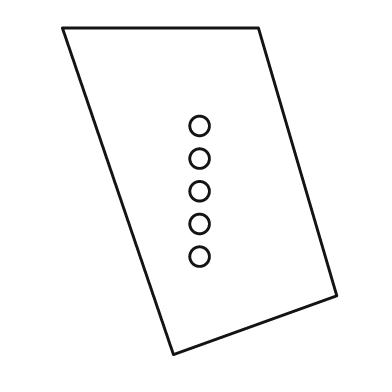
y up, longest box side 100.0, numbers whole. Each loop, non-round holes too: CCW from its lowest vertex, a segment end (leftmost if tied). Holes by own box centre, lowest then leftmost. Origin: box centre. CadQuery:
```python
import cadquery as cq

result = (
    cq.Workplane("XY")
    .moveTo(-8.0, -50.0)
    .lineTo(42.0, -32.0)
    .lineTo(18.0, 50.0)
    .lineTo(-42.0, 50.0)
    .close()
    .moveTo(0.0, -20.0)
    .circle(3.0)
    .moveTo(0.0, -10.0)
    .circle(3.0)
    .moveTo(0.0, 0.0)
    .circle(3.0)
    .moveTo(0.0, 10.0)
    .circle(3.0)
    .moveTo(0.0, 20.0)
    .circle(3.0)
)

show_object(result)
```